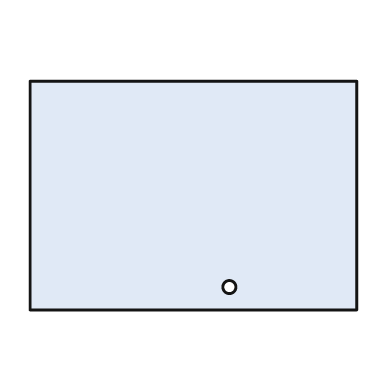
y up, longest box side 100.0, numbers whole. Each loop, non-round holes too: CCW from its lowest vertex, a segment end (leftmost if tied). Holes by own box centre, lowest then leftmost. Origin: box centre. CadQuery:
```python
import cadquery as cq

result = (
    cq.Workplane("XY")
    .moveTo(-50.0, -35.0)
    .lineTo(50.0, -35.0)
    .lineTo(50.0, 35.0)
    .lineTo(-50.0, 35.0)
    .close()
    .moveTo(11.0, -28.0)
    .circle(2.0)
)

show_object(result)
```